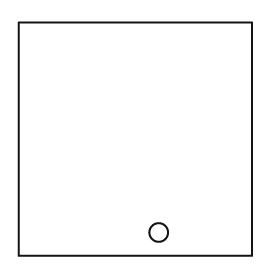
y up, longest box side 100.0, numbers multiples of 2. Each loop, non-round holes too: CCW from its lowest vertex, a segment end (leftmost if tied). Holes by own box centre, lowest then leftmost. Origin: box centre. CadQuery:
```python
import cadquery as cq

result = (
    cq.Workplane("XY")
    .moveTo(-50.0, -50.0)
    .lineTo(50.0, -50.0)
    .lineTo(50.0, 50.0)
    .lineTo(-50.0, 50.0)
    .close()
    .moveTo(10.0, -40.0)
    .circle(4.0)
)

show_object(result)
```